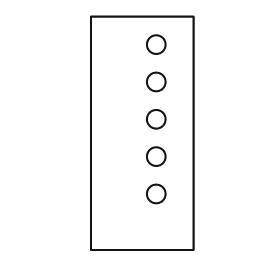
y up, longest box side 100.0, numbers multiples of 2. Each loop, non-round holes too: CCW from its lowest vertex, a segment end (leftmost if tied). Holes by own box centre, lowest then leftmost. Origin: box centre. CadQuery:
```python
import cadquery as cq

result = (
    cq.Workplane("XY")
    .moveTo(-22.0, -50.0)
    .lineTo(22.0, -50.0)
    .lineTo(22.0, 50.0)
    .lineTo(-22.0, 50.0)
    .close()
    .moveTo(6.0, -26.0)
    .circle(4.0)
    .moveTo(6.0, -10.0)
    .circle(4.0)
    .moveTo(6.0, 6.0)
    .circle(4.0)
    .moveTo(6.0, 22.0)
    .circle(4.0)
    .moveTo(6.0, 38.0)
    .circle(4.0)
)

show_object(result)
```